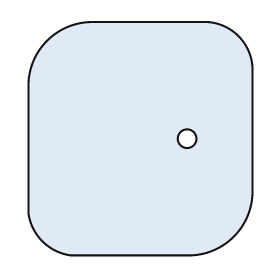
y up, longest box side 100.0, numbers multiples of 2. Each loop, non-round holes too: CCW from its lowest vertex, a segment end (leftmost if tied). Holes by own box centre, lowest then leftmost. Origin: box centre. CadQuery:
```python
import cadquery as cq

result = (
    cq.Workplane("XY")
    .moveTo(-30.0, -50.0)
    .lineTo(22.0, -50.0)
    .threePointArc((40.0, -42.0), (48.0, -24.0))
    .lineTo(48.0, 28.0)
    .threePointArc((42.0, 44.0), (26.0, 50.0))
    .lineTo(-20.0, 50.0)
    .threePointArc((-40.0, 42.0), (-48.0, 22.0))
    .lineTo(-48.0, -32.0)
    .threePointArc((-42.0, -44.0), (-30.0, -50.0))
    .close()
    .moveTo(20.0, 0.0)
    .circle(4.0)
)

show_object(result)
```